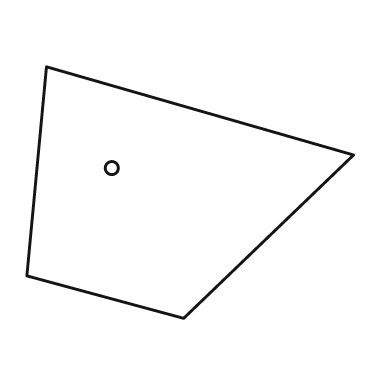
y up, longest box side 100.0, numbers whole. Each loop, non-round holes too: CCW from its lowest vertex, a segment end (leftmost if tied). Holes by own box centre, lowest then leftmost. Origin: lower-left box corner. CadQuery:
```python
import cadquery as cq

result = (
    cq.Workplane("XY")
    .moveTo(48.0, 0.0)
    .lineTo(100.0, 50.0)
    .lineTo(6.0, 77.0)
    .lineTo(0.0, 13.0)
    .close()
    .moveTo(26.0, 46.0)
    .circle(2.0)
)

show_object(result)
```